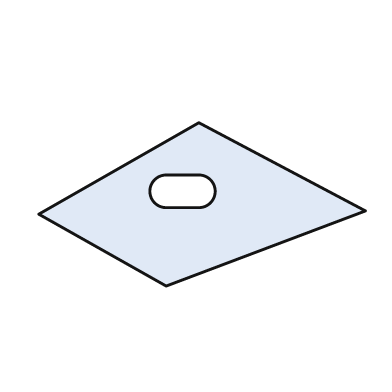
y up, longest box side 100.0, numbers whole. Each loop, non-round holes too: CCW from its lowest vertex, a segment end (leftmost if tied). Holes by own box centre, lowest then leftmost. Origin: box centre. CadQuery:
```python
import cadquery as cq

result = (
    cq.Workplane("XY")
    .moveTo(-11.0, -25.0)
    .lineTo(50.0, -2.0)
    .lineTo(-1.0, 25.0)
    .lineTo(-50.0, -3.0)
    .close()
    .moveTo(-11.0, -1.0)
    .lineTo(-1.0, -1.0)
    .threePointArc((4.0, 4.0), (-1.0, 9.0))
    .lineTo(-11.0, 9.0)
    .threePointArc((-16.0, 4.0), (-11.0, -1.0))
    .close()
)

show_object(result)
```